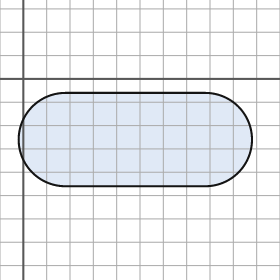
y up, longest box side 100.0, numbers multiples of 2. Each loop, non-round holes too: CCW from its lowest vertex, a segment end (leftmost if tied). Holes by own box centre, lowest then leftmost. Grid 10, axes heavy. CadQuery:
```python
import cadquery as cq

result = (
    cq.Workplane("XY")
    .moveTo(18.0, -46.0)
    .lineTo(78.0, -46.0)
    .threePointArc((98.0, -26.0), (78.0, -6.0))
    .lineTo(18.0, -6.0)
    .threePointArc((-2.0, -26.0), (18.0, -46.0))
    .close()
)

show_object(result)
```